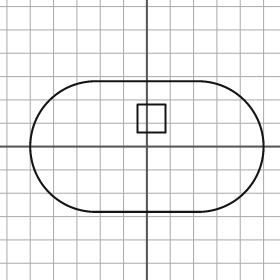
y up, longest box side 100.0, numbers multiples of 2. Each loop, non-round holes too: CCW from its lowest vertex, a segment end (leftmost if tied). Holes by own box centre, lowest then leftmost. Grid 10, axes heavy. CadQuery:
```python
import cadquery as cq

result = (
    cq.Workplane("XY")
    .moveTo(-22.0, -28.0)
    .lineTo(22.0, -28.0)
    .threePointArc((50.0, 0.0), (22.0, 28.0))
    .lineTo(-22.0, 28.0)
    .threePointArc((-50.0, 0.0), (-22.0, -28.0))
    .close()
    .moveTo(-4.0, 6.0)
    .lineTo(8.0, 6.0)
    .lineTo(8.0, 18.0)
    .lineTo(-4.0, 18.0)
    .close()
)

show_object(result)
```